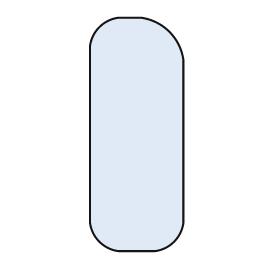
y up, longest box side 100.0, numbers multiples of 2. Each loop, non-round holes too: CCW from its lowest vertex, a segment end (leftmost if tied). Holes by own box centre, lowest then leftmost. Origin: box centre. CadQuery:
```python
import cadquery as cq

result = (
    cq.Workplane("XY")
    .moveTo(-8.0, -50.0)
    .lineTo(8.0, -50.0)
    .threePointArc((16.0, -46.0), (20.0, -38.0))
    .lineTo(20.0, 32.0)
    .threePointArc((14.0, 44.0), (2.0, 50.0))
    .lineTo(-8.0, 50.0)
    .threePointArc((-16.0, 46.0), (-20.0, 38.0))
    .lineTo(-20.0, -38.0)
    .threePointArc((-16.0, -46.0), (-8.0, -50.0))
    .close()
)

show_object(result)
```